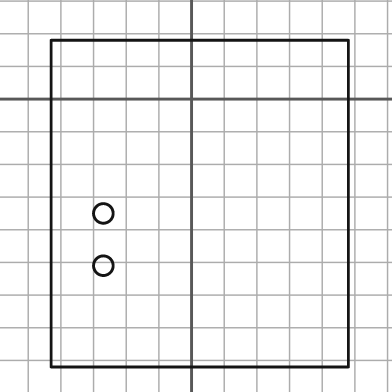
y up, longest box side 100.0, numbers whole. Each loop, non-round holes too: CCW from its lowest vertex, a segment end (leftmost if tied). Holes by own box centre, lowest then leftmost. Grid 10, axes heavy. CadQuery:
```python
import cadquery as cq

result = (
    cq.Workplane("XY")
    .moveTo(-43.0, -82.0)
    .lineTo(48.0, -82.0)
    .lineTo(48.0, 18.0)
    .lineTo(-43.0, 18.0)
    .close()
    .moveTo(-27.0, -51.0)
    .circle(3.0)
    .moveTo(-27.0, -35.0)
    .circle(3.0)
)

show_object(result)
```